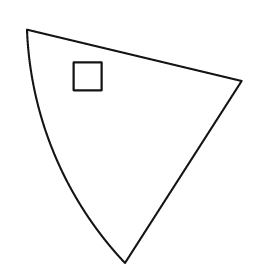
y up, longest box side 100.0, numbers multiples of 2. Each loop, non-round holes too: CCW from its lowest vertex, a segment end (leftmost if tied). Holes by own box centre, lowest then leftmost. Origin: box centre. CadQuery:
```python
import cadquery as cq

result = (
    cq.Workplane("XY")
    .moveTo(-4.0, -50.0)
    .lineTo(46.0, 28.0)
    .lineTo(-46.0, 50.0)
    .threePointArc((-34.0, -4.0), (-4.0, -50.0))
    .close()
    .moveTo(-26.0, 24.0)
    .lineTo(-14.0, 24.0)
    .lineTo(-14.0, 36.0)
    .lineTo(-26.0, 36.0)
    .close()
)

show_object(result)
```